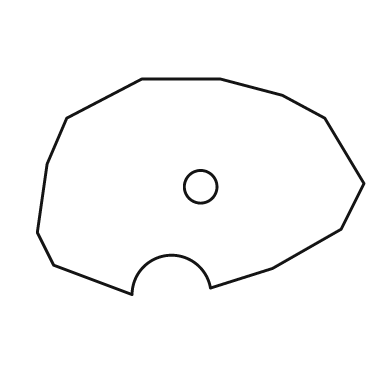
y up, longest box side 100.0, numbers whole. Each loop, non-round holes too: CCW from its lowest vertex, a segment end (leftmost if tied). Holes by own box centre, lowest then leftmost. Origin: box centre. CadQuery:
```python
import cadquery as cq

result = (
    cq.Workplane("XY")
    .moveTo(-21.0, -33.0)
    .threePointArc((-10.0, -21.0), (3.0, -31.0))
    .lineTo(22.0, -25.0)
    .lineTo(43.0, -13.0)
    .lineTo(50.0, 1.0)
    .lineTo(38.0, 21.0)
    .lineTo(25.0, 28.0)
    .lineTo(6.0, 33.0)
    .lineTo(-18.0, 33.0)
    .lineTo(-41.0, 21.0)
    .lineTo(-47.0, 7.0)
    .lineTo(-50.0, -14.0)
    .lineTo(-45.0, -24.0)
    .close()
    .moveTo(0.0, 0.0)
    .circle(5.0)
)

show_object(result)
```